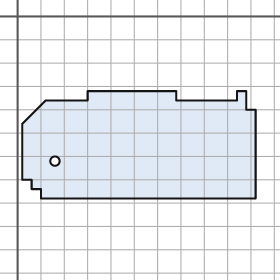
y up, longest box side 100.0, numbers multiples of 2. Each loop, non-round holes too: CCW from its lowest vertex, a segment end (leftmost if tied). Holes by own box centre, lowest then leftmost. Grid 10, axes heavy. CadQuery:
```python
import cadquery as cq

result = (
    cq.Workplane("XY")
    .moveTo(10.0, -78.0)
    .lineTo(102.0, -78.0)
    .lineTo(102.0, -40.0)
    .lineTo(98.0, -40.0)
    .lineTo(98.0, -32.0)
    .lineTo(94.0, -32.0)
    .lineTo(94.0, -36.0)
    .lineTo(68.0, -36.0)
    .lineTo(68.0, -32.0)
    .lineTo(30.0, -32.0)
    .lineTo(30.0, -36.0)
    .lineTo(12.0, -36.0)
    .lineTo(2.0, -46.0)
    .lineTo(2.0, -70.0)
    .lineTo(6.0, -70.0)
    .lineTo(6.0, -74.0)
    .lineTo(10.0, -74.0)
    .close()
    .moveTo(16.0, -62.0)
    .circle(2.0)
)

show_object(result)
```